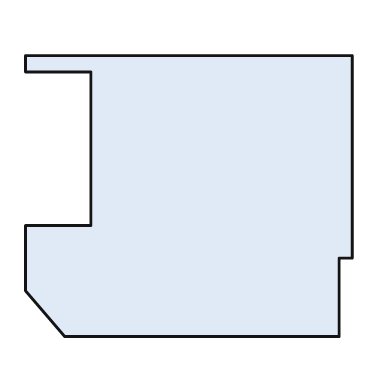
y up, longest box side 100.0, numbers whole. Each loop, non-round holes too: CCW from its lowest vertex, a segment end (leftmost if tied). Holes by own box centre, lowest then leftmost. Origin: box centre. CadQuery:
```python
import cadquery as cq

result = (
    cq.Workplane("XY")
    .moveTo(-38.0, -43.0)
    .lineTo(46.0, -43.0)
    .lineTo(46.0, -19.0)
    .lineTo(50.0, -19.0)
    .lineTo(50.0, 43.0)
    .lineTo(-50.0, 43.0)
    .lineTo(-50.0, 38.0)
    .lineTo(-30.0, 38.0)
    .lineTo(-30.0, -9.0)
    .lineTo(-50.0, -9.0)
    .lineTo(-50.0, -29.0)
    .close()
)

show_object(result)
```